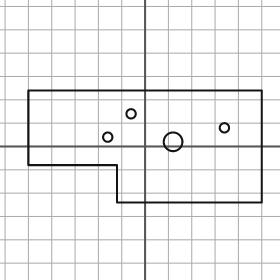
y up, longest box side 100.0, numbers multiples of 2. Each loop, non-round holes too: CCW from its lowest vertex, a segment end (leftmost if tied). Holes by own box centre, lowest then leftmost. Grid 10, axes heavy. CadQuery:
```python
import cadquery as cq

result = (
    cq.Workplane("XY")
    .moveTo(-12.0, -24.0)
    .lineTo(50.0, -24.0)
    .lineTo(50.0, 24.0)
    .lineTo(-50.0, 24.0)
    .lineTo(-50.0, -8.0)
    .lineTo(-12.0, -8.0)
    .close()
    .moveTo(12.0, 2.0)
    .circle(4.0)
    .moveTo(-16.0, 4.0)
    .circle(2.0)
    .moveTo(34.0, 8.0)
    .circle(2.0)
    .moveTo(-6.0, 14.0)
    .circle(2.0)
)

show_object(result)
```